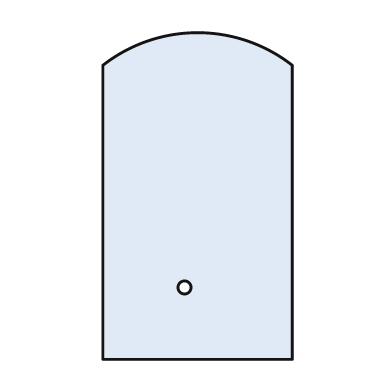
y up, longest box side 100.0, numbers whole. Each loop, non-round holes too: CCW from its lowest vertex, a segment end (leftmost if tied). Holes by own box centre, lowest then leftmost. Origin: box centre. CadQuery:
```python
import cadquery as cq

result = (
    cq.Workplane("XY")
    .moveTo(-29.0, -50.0)
    .lineTo(29.0, -50.0)
    .lineTo(29.0, 40.0)
    .threePointArc((0.0, 50.0), (-29.0, 40.0))
    .close()
    .moveTo(-4.0, -28.0)
    .circle(2.0)
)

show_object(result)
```